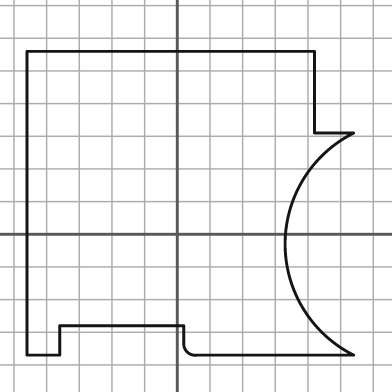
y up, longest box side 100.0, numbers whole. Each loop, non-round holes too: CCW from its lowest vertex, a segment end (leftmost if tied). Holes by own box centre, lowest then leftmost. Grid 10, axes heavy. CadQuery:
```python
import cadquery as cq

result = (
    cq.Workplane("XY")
    .moveTo(-46.0, -37.0)
    .lineTo(-36.0, -37.0)
    .lineTo(-36.0, -28.0)
    .lineTo(2.0, -28.0)
    .lineTo(2.0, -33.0)
    .threePointArc((3.0, -36.0), (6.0, -37.0))
    .lineTo(54.0, -37.0)
    .threePointArc((33.0, -3.0), (54.0, 31.0))
    .lineTo(42.0, 31.0)
    .lineTo(42.0, 56.0)
    .lineTo(-46.0, 56.0)
    .close()
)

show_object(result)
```